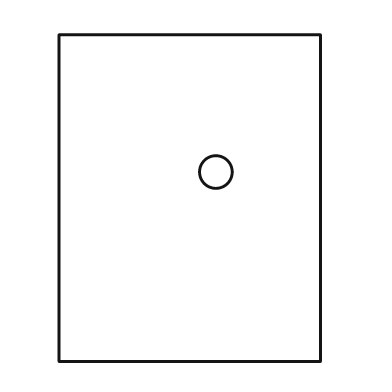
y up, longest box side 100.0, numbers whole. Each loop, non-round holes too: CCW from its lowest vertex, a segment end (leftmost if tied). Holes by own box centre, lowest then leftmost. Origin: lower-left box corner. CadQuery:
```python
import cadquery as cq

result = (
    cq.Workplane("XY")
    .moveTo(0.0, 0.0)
    .lineTo(80.0, 0.0)
    .lineTo(80.0, 100.0)
    .lineTo(0.0, 100.0)
    .close()
    .moveTo(48.0, 58.0)
    .circle(5.0)
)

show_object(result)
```